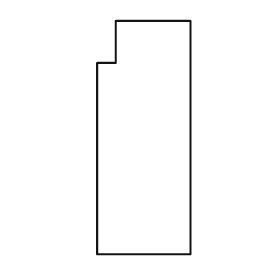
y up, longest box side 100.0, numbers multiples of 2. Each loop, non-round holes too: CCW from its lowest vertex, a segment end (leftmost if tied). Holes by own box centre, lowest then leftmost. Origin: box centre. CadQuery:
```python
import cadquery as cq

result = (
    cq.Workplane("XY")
    .moveTo(-20.0, -50.0)
    .lineTo(20.0, -50.0)
    .lineTo(20.0, 50.0)
    .lineTo(-12.0, 50.0)
    .lineTo(-12.0, 32.0)
    .lineTo(-20.0, 32.0)
    .close()
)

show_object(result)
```